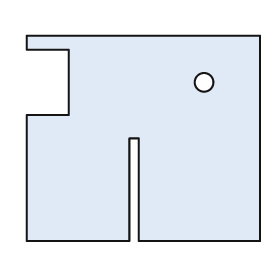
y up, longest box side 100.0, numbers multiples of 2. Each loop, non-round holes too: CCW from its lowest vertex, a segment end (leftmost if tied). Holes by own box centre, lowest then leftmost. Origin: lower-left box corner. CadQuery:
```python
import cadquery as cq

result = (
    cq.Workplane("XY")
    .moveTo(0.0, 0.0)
    .lineTo(44.0, 0.0)
    .lineTo(44.0, 44.0)
    .lineTo(48.0, 44.0)
    .lineTo(48.0, 0.0)
    .lineTo(100.0, 0.0)
    .lineTo(100.0, 88.0)
    .lineTo(0.0, 88.0)
    .lineTo(0.0, 82.0)
    .lineTo(18.0, 82.0)
    .lineTo(18.0, 54.0)
    .lineTo(0.0, 54.0)
    .close()
    .moveTo(76.0, 68.0)
    .circle(4.0)
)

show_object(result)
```